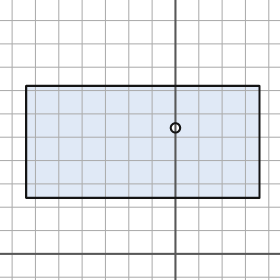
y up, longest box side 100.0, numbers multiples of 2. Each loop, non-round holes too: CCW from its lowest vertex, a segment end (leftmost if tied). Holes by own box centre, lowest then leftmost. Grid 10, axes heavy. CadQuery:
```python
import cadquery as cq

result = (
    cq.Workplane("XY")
    .moveTo(-64.0, 24.0)
    .lineTo(36.0, 24.0)
    .lineTo(36.0, 72.0)
    .lineTo(-64.0, 72.0)
    .close()
    .moveTo(0.0, 54.0)
    .circle(2.0)
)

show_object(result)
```